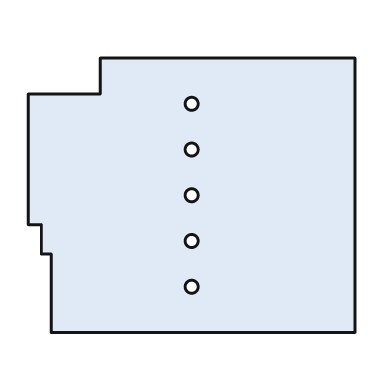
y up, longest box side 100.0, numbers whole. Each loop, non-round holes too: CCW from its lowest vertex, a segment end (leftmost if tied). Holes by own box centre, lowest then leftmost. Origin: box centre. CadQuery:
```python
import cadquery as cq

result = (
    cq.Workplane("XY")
    .moveTo(-43.0, -42.0)
    .lineTo(50.0, -42.0)
    .lineTo(50.0, 42.0)
    .lineTo(-28.0, 42.0)
    .lineTo(-28.0, 31.0)
    .lineTo(-50.0, 31.0)
    .lineTo(-50.0, -9.0)
    .lineTo(-46.0, -9.0)
    .lineTo(-46.0, -18.0)
    .lineTo(-43.0, -18.0)
    .close()
    .moveTo(0.0, -28.0)
    .circle(2.0)
    .moveTo(0.0, -14.0)
    .circle(2.0)
    .moveTo(0.0, 0.0)
    .circle(2.0)
    .moveTo(0.0, 14.0)
    .circle(2.0)
    .moveTo(0.0, 28.0)
    .circle(2.0)
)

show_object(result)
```